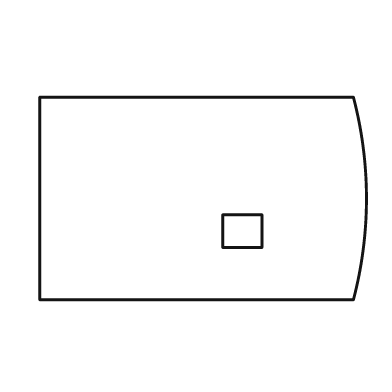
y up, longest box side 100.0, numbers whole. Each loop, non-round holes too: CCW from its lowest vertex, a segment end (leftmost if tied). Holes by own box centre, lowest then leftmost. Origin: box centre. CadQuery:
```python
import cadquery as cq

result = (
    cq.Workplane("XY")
    .moveTo(-50.0, -31.0)
    .lineTo(46.0, -31.0)
    .threePointArc((50.0, 0.0), (46.0, 31.0))
    .lineTo(-50.0, 31.0)
    .close()
    .moveTo(6.0, -15.0)
    .lineTo(18.0, -15.0)
    .lineTo(18.0, -5.0)
    .lineTo(6.0, -5.0)
    .close()
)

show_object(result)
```